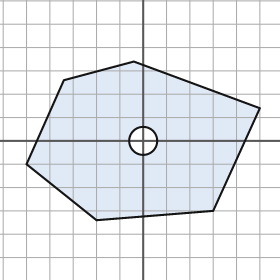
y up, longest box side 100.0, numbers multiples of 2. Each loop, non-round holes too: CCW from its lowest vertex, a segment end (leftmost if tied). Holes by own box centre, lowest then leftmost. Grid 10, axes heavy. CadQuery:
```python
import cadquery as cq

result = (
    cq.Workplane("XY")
    .moveTo(-20.0, -34.0)
    .lineTo(30.0, -30.0)
    .lineTo(50.0, 14.0)
    .lineTo(-4.0, 34.0)
    .lineTo(-34.0, 26.0)
    .lineTo(-50.0, -10.0)
    .close()
    .moveTo(0.0, 0.0)
    .circle(6.0)
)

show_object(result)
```